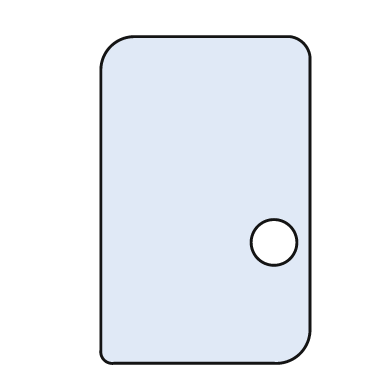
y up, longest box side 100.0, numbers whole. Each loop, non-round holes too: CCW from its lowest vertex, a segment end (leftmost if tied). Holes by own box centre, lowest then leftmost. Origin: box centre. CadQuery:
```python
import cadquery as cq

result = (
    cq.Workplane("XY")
    .moveTo(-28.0, -50.0)
    .lineTo(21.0, -50.0)
    .threePointArc((29.0, -47.0), (32.0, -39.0))
    .lineTo(32.0, 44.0)
    .threePointArc((30.0, 48.0), (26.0, 50.0))
    .lineTo(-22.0, 50.0)
    .threePointArc((-29.0, 47.0), (-32.0, 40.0))
    .lineTo(-32.0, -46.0)
    .threePointArc((-31.0, -49.0), (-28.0, -50.0))
    .close()
    .moveTo(21.0, -13.0)
    .circle(7.0)
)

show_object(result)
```